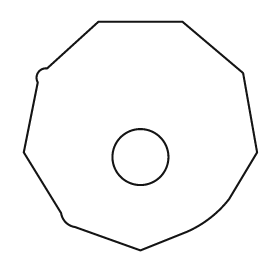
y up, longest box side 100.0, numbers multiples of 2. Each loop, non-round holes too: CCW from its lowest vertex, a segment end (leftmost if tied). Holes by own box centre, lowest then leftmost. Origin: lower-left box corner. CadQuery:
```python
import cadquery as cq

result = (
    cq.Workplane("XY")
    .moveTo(50.0, 0.0)
    .lineTo(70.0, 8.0)
    .threePointArc((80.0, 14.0), (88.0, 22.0))
    .lineTo(100.0, 42.0)
    .lineTo(94.0, 76.0)
    .lineTo(68.0, 98.0)
    .lineTo(32.0, 98.0)
    .lineTo(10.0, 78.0)
    .threePointArc((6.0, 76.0), (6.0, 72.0))
    .lineTo(0.0, 42.0)
    .lineTo(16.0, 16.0)
    .threePointArc((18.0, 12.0), (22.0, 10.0))
    .close()
    .moveTo(50.0, 40.0)
    .circle(12.0)
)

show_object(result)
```